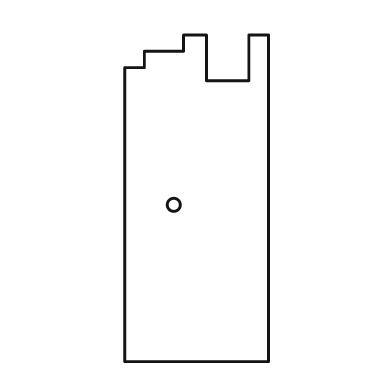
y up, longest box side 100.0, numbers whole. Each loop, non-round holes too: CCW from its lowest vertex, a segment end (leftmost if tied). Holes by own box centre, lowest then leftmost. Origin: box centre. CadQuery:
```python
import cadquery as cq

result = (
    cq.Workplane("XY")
    .moveTo(-22.0, -50.0)
    .lineTo(22.0, -50.0)
    .lineTo(22.0, 50.0)
    .lineTo(16.0, 50.0)
    .lineTo(16.0, 36.0)
    .lineTo(3.0, 36.0)
    .lineTo(3.0, 50.0)
    .lineTo(-4.0, 50.0)
    .lineTo(-4.0, 45.0)
    .lineTo(-16.0, 45.0)
    .lineTo(-16.0, 40.0)
    .lineTo(-22.0, 40.0)
    .close()
    .moveTo(-7.0, -2.0)
    .circle(2.0)
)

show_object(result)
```